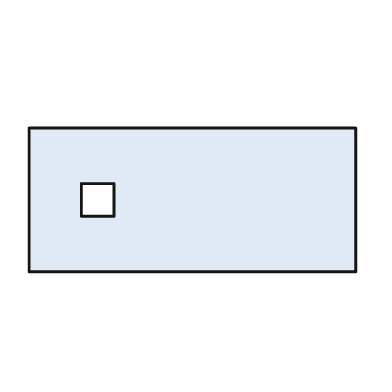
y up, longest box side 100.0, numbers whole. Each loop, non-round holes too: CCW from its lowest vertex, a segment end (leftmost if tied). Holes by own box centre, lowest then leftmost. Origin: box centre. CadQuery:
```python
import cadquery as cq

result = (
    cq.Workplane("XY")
    .moveTo(-50.0, -22.0)
    .lineTo(50.0, -22.0)
    .lineTo(50.0, 22.0)
    .lineTo(-50.0, 22.0)
    .close()
    .moveTo(-34.0, -5.0)
    .lineTo(-24.0, -5.0)
    .lineTo(-24.0, 5.0)
    .lineTo(-34.0, 5.0)
    .close()
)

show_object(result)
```